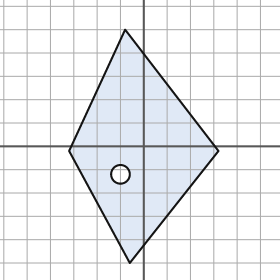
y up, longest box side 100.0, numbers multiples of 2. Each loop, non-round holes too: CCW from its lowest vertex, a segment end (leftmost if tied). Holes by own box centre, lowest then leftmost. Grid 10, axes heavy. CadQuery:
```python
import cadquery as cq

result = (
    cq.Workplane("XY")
    .moveTo(-6.0, -50.0)
    .lineTo(32.0, -2.0)
    .lineTo(-8.0, 50.0)
    .lineTo(-32.0, -2.0)
    .close()
    .moveTo(-10.0, -12.0)
    .circle(4.0)
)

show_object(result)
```